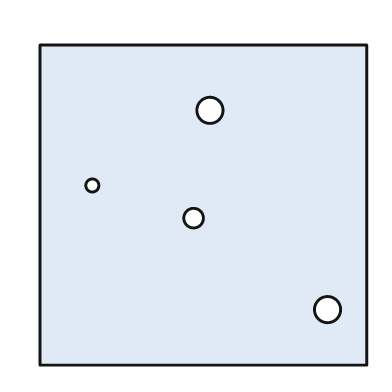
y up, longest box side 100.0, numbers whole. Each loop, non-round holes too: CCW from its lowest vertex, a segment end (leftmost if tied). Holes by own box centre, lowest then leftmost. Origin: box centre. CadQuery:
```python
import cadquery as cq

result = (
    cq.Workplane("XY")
    .moveTo(-50.0, -49.0)
    .lineTo(50.0, -49.0)
    .lineTo(50.0, 49.0)
    .lineTo(-50.0, 49.0)
    .close()
    .moveTo(38.0, -32.0)
    .circle(4.0)
    .moveTo(-3.0, -4.0)
    .circle(3.0)
    .moveTo(-34.0, 6.0)
    .circle(2.0)
    .moveTo(2.0, 29.0)
    .circle(4.0)
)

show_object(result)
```